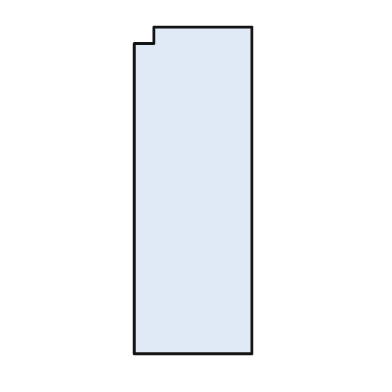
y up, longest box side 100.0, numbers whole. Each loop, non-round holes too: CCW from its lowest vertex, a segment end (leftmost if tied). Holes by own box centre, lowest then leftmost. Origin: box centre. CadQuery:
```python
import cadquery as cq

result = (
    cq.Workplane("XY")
    .moveTo(-18.0, -50.0)
    .lineTo(18.0, -50.0)
    .lineTo(18.0, 50.0)
    .lineTo(-12.0, 50.0)
    .lineTo(-12.0, 45.0)
    .lineTo(-18.0, 45.0)
    .close()
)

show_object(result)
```